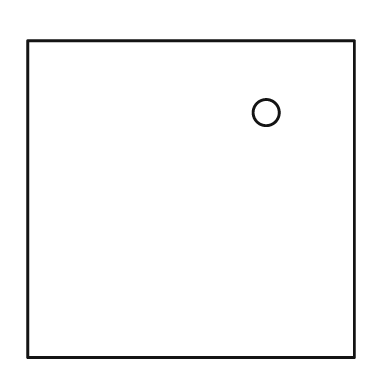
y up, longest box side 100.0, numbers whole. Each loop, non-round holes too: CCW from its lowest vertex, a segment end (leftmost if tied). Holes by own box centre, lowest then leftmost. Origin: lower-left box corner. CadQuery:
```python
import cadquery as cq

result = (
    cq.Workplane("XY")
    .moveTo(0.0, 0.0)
    .lineTo(100.0, 0.0)
    .lineTo(100.0, 97.0)
    .lineTo(0.0, 97.0)
    .close()
    .moveTo(73.0, 75.0)
    .circle(4.0)
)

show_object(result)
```